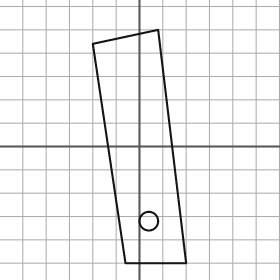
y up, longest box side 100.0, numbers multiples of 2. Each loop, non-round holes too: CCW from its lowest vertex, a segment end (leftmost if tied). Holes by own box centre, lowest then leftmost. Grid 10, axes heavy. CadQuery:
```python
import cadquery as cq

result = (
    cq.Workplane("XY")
    .moveTo(-6.0, -50.0)
    .lineTo(20.0, -50.0)
    .lineTo(8.0, 50.0)
    .lineTo(-20.0, 44.0)
    .close()
    .moveTo(4.0, -32.0)
    .circle(4.0)
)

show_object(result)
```